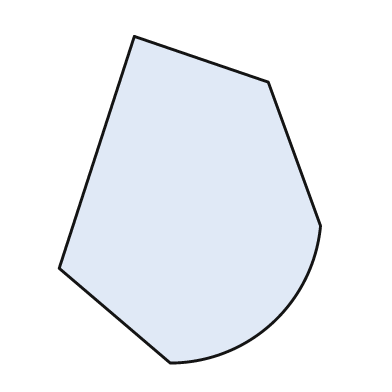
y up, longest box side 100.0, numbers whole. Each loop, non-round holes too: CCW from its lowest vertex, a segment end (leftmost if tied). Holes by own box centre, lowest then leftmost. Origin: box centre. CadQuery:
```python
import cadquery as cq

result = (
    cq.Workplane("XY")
    .moveTo(-6.0, -50.0)
    .threePointArc((25.0, -38.0), (40.0, -8.0))
    .lineTo(24.0, 36.0)
    .lineTo(-17.0, 50.0)
    .lineTo(-40.0, -21.0)
    .close()
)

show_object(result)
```